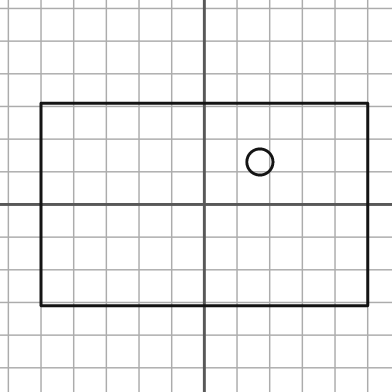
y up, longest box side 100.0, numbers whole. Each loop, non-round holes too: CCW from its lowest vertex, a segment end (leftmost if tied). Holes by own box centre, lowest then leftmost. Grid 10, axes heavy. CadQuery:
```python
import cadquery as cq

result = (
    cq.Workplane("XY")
    .moveTo(-50.0, -31.0)
    .lineTo(50.0, -31.0)
    .lineTo(50.0, 31.0)
    .lineTo(-50.0, 31.0)
    .close()
    .moveTo(17.0, 13.0)
    .circle(4.0)
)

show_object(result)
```